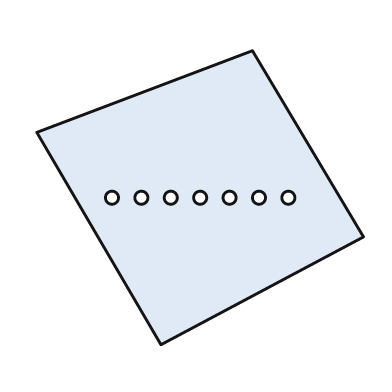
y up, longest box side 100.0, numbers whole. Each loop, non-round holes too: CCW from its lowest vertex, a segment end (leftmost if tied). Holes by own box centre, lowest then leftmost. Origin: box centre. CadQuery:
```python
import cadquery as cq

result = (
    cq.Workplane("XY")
    .moveTo(-12.0, -45.0)
    .lineTo(50.0, -12.0)
    .lineTo(16.0, 45.0)
    .lineTo(-50.0, 20.0)
    .close()
    .moveTo(-27.0, 0.0)
    .circle(2.0)
    .moveTo(-18.0, 0.0)
    .circle(2.0)
    .moveTo(-9.0, 0.0)
    .circle(2.0)
    .moveTo(0.0, 0.0)
    .circle(2.0)
    .moveTo(9.0, 0.0)
    .circle(2.0)
    .moveTo(18.0, 0.0)
    .circle(2.0)
    .moveTo(27.0, 0.0)
    .circle(2.0)
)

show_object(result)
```